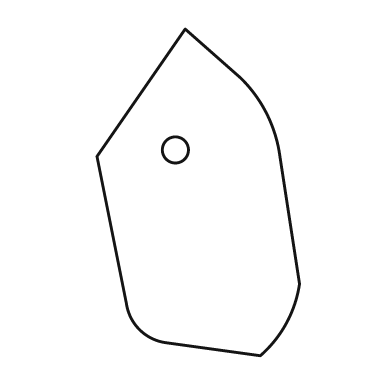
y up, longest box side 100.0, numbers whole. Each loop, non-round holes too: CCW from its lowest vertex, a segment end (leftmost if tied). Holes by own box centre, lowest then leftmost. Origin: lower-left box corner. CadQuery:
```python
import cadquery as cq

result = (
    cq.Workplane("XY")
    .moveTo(50.0, 0.0)
    .threePointArc((58.0, 10.0), (62.0, 22.0))
    .lineTo(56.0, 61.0)
    .threePointArc((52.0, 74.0), (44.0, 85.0))
    .lineTo(27.0, 100.0)
    .lineTo(0.0, 61.0)
    .lineTo(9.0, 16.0)
    .threePointArc((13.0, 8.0), (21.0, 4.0))
    .close()
    .moveTo(24.0, 63.0)
    .circle(4.0)
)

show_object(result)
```